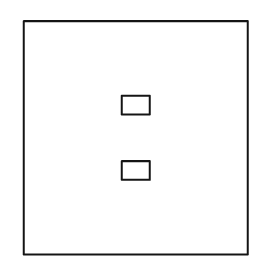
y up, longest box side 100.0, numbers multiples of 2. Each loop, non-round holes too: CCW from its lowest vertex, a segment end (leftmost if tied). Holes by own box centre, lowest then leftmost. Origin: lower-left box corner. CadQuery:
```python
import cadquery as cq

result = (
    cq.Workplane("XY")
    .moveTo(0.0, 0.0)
    .lineTo(96.0, 0.0)
    .lineTo(96.0, 100.0)
    .lineTo(0.0, 100.0)
    .close()
    .moveTo(42.0, 32.0)
    .lineTo(54.0, 32.0)
    .lineTo(54.0, 40.0)
    .lineTo(42.0, 40.0)
    .close()
    .moveTo(42.0, 60.0)
    .lineTo(54.0, 60.0)
    .lineTo(54.0, 68.0)
    .lineTo(42.0, 68.0)
    .close()
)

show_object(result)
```